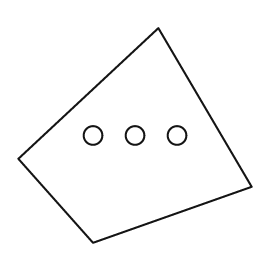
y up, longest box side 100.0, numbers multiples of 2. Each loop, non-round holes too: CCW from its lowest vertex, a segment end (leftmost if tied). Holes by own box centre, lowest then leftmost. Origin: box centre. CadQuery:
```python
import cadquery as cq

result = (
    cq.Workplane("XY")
    .moveTo(-18.0, -46.0)
    .lineTo(50.0, -22.0)
    .lineTo(10.0, 46.0)
    .lineTo(-50.0, -10.0)
    .close()
    .moveTo(-18.0, 0.0)
    .circle(4.0)
    .moveTo(0.0, 0.0)
    .circle(4.0)
    .moveTo(18.0, 0.0)
    .circle(4.0)
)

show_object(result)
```